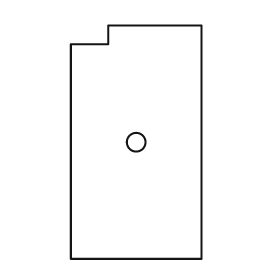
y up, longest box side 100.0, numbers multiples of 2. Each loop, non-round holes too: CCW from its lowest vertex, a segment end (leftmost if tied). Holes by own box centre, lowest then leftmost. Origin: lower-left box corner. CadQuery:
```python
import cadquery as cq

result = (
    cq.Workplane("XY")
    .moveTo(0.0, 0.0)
    .lineTo(56.0, 0.0)
    .lineTo(56.0, 100.0)
    .lineTo(16.0, 100.0)
    .lineTo(16.0, 92.0)
    .lineTo(0.0, 92.0)
    .close()
    .moveTo(28.0, 50.0)
    .circle(4.0)
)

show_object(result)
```